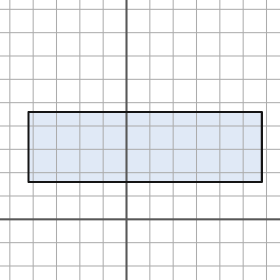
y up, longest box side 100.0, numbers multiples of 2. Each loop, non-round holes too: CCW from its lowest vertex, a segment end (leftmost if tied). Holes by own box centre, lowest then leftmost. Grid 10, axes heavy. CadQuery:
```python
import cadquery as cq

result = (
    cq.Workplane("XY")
    .moveTo(-42.0, 16.0)
    .lineTo(58.0, 16.0)
    .lineTo(58.0, 46.0)
    .lineTo(-42.0, 46.0)
    .close()
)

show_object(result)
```